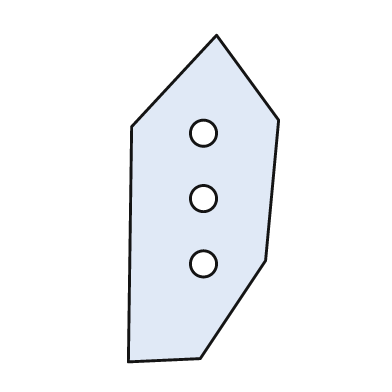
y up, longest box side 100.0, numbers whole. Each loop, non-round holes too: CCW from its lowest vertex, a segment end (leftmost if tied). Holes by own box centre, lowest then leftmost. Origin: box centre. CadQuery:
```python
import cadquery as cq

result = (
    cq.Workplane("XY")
    .moveTo(-23.0, -50.0)
    .lineTo(-1.0, -49.0)
    .lineTo(19.0, -19.0)
    .lineTo(23.0, 24.0)
    .lineTo(4.0, 50.0)
    .lineTo(-22.0, 22.0)
    .close()
    .moveTo(0.0, -20.0)
    .circle(4.0)
    .moveTo(0.0, 0.0)
    .circle(4.0)
    .moveTo(0.0, 20.0)
    .circle(4.0)
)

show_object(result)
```